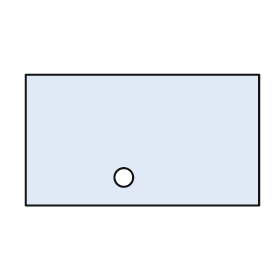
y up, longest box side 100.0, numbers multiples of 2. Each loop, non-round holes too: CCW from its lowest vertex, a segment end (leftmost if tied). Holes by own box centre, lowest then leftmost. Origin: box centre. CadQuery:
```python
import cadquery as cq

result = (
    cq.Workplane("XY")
    .moveTo(-50.0, -28.0)
    .lineTo(50.0, -28.0)
    .lineTo(50.0, 28.0)
    .lineTo(-50.0, 28.0)
    .close()
    .moveTo(-8.0, -16.0)
    .circle(4.0)
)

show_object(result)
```